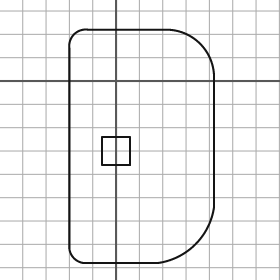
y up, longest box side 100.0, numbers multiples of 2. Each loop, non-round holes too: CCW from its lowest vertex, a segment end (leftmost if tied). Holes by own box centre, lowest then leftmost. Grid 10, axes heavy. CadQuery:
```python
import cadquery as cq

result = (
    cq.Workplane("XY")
    .moveTo(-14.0, -78.0)
    .lineTo(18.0, -78.0)
    .threePointArc((34.0, -70.0), (42.0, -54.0))
    .lineTo(42.0, 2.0)
    .threePointArc((36.0, 16.0), (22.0, 22.0))
    .lineTo(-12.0, 22.0)
    .threePointArc((-18.0, 20.0), (-20.0, 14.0))
    .lineTo(-20.0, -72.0)
    .threePointArc((-18.0, -76.0), (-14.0, -78.0))
    .close()
    .moveTo(-6.0, -36.0)
    .lineTo(6.0, -36.0)
    .lineTo(6.0, -24.0)
    .lineTo(-6.0, -24.0)
    .close()
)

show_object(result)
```